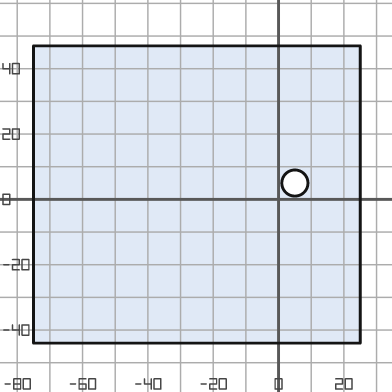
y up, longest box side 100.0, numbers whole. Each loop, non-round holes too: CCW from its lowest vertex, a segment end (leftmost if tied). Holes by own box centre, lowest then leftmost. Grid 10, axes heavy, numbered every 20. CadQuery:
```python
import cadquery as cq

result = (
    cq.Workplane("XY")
    .moveTo(-75.0, -44.0)
    .lineTo(25.0, -44.0)
    .lineTo(25.0, 47.0)
    .lineTo(-75.0, 47.0)
    .close()
    .moveTo(5.0, 5.0)
    .circle(4.0)
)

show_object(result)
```